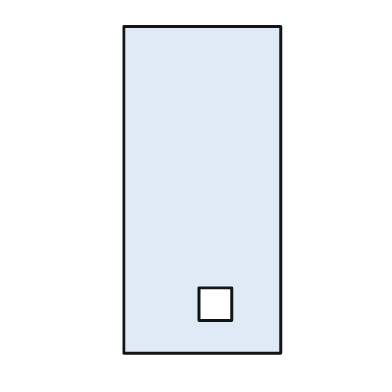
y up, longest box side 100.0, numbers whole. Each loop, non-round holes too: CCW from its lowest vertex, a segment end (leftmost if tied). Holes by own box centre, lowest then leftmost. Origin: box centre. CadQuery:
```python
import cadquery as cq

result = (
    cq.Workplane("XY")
    .moveTo(-24.0, -50.0)
    .lineTo(24.0, -50.0)
    .lineTo(24.0, 50.0)
    .lineTo(-24.0, 50.0)
    .close()
    .moveTo(-1.0, -40.0)
    .lineTo(9.0, -40.0)
    .lineTo(9.0, -30.0)
    .lineTo(-1.0, -30.0)
    .close()
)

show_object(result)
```